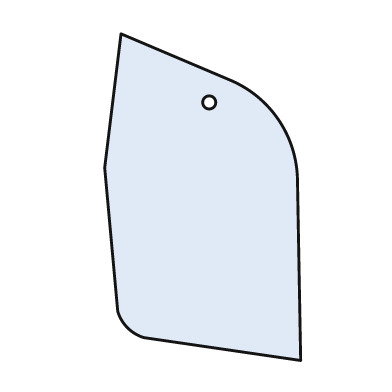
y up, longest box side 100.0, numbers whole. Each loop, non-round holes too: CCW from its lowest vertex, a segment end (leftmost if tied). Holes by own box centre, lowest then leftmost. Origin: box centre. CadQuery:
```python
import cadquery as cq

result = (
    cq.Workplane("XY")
    .moveTo(30.0, -50.0)
    .lineTo(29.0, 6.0)
    .threePointArc((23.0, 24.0), (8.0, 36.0))
    .lineTo(-25.0, 50.0)
    .lineTo(-30.0, 9.0)
    .lineTo(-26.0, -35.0)
    .threePointArc((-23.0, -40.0), (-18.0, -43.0))
    .close()
    .moveTo(2.0, 29.0)
    .circle(2.0)
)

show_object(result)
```